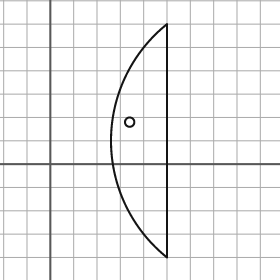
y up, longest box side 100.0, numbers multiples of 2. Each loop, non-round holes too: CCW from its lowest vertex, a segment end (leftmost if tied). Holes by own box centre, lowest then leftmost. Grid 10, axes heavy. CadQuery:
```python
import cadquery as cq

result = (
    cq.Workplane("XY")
    .moveTo(50.0, -40.0)
    .lineTo(50.0, 60.0)
    .threePointArc((26.0, 10.0), (50.0, -40.0))
    .close()
    .moveTo(34.0, 18.0)
    .circle(2.0)
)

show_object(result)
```